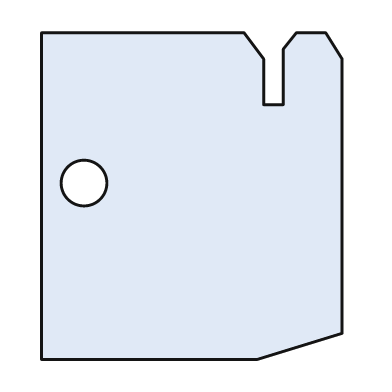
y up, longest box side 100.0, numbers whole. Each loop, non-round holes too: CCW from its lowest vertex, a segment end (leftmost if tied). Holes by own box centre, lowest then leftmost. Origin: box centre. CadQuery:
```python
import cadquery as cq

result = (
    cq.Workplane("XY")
    .moveTo(-46.0, -50.0)
    .lineTo(20.0, -50.0)
    .lineTo(46.0, -42.0)
    .lineTo(46.0, 42.0)
    .lineTo(41.0, 50.0)
    .lineTo(32.0, 50.0)
    .lineTo(28.0, 45.0)
    .lineTo(28.0, 28.0)
    .lineTo(22.0, 28.0)
    .lineTo(22.0, 42.0)
    .lineTo(16.0, 50.0)
    .lineTo(-46.0, 50.0)
    .close()
    .moveTo(-33.0, 4.0)
    .circle(7.0)
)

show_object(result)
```